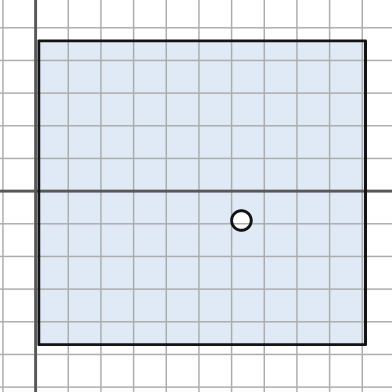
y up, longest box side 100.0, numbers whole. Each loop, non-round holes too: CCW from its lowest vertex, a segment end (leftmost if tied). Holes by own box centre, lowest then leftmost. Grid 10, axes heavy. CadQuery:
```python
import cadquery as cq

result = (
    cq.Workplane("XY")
    .moveTo(1.0, -47.0)
    .lineTo(101.0, -47.0)
    .lineTo(101.0, 46.0)
    .lineTo(1.0, 46.0)
    .close()
    .moveTo(63.0, -9.0)
    .circle(3.0)
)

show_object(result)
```